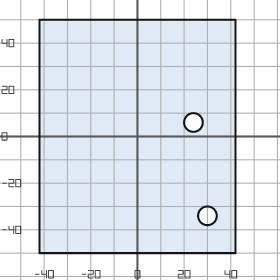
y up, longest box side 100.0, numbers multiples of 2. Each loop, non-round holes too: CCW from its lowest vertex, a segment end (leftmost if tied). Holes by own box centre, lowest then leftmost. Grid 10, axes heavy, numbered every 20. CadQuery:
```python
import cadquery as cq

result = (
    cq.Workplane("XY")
    .moveTo(-42.0, -50.0)
    .lineTo(42.0, -50.0)
    .lineTo(42.0, 50.0)
    .lineTo(-42.0, 50.0)
    .close()
    .moveTo(30.0, -34.0)
    .circle(4.0)
    .moveTo(24.0, 6.0)
    .circle(4.0)
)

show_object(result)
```